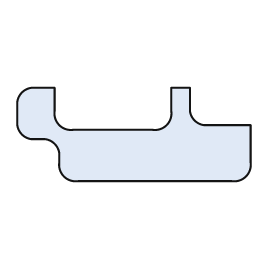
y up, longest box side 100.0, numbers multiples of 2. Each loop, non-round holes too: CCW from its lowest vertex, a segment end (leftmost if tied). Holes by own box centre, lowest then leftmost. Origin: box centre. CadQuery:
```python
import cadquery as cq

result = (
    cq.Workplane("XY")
    .moveTo(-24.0, -20.0)
    .lineTo(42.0, -20.0)
    .threePointArc((48.0, -18.0), (50.0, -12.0))
    .lineTo(50.0, 4.0)
    .lineTo(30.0, 4.0)
    .threePointArc((26.0, 6.0), (24.0, 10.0))
    .lineTo(24.0, 20.0)
    .lineTo(16.0, 20.0)
    .lineTo(16.0, 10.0)
    .threePointArc((14.0, 4.0), (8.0, 2.0))
    .lineTo(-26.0, 2.0)
    .threePointArc((-32.0, 4.0), (-34.0, 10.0))
    .lineTo(-34.0, 20.0)
    .lineTo(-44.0, 20.0)
    .threePointArc((-48.0, 18.0), (-50.0, 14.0))
    .lineTo(-50.0, 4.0)
    .threePointArc((-48.0, 0.0), (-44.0, -2.0))
    .lineTo(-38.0, -2.0)
    .threePointArc((-34.0, -4.0), (-32.0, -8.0))
    .lineTo(-32.0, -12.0)
    .threePointArc((-30.0, -18.0), (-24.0, -20.0))
    .close()
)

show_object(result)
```